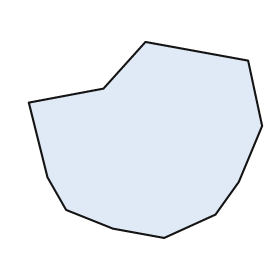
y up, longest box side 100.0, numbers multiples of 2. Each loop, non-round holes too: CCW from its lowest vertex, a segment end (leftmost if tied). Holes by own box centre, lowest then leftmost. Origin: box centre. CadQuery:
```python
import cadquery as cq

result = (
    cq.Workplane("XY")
    .moveTo(8.0, -42.0)
    .lineTo(30.0, -32.0)
    .lineTo(40.0, -18.0)
    .lineTo(50.0, 6.0)
    .lineTo(44.0, 34.0)
    .lineTo(0.0, 42.0)
    .lineTo(-18.0, 22.0)
    .lineTo(-50.0, 16.0)
    .lineTo(-42.0, -16.0)
    .lineTo(-34.0, -30.0)
    .lineTo(-14.0, -38.0)
    .close()
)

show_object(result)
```